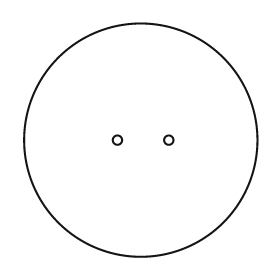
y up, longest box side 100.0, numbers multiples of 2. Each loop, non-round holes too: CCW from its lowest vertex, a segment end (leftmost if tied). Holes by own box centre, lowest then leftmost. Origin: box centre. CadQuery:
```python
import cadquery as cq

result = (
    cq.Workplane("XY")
    .moveTo(0.0, 0.0)
    .circle(50.0)
    .moveTo(-10.0, 0.0)
    .circle(2.0)
    .moveTo(12.0, 0.0)
    .circle(2.0)
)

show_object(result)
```